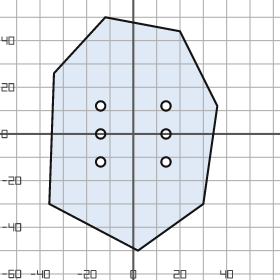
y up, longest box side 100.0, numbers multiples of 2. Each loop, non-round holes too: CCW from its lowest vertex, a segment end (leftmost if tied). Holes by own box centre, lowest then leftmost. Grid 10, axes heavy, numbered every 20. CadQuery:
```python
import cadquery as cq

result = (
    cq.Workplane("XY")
    .moveTo(2.0, -50.0)
    .lineTo(30.0, -30.0)
    .lineTo(36.0, 12.0)
    .lineTo(20.0, 44.0)
    .lineTo(-12.0, 50.0)
    .lineTo(-34.0, 26.0)
    .lineTo(-36.0, -30.0)
    .close()
    .moveTo(-14.0, -12.0)
    .circle(2.0)
    .moveTo(14.0, -12.0)
    .circle(2.0)
    .moveTo(-14.0, 0.0)
    .circle(2.0)
    .moveTo(14.0, 0.0)
    .circle(2.0)
    .moveTo(-14.0, 12.0)
    .circle(2.0)
    .moveTo(14.0, 12.0)
    .circle(2.0)
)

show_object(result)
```